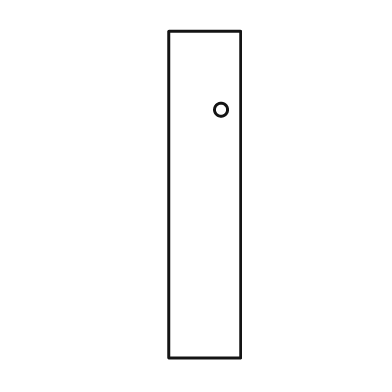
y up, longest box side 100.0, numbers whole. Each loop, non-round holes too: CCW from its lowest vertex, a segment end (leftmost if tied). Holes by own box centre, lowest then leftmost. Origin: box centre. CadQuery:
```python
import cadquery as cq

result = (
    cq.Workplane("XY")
    .moveTo(-11.0, -50.0)
    .lineTo(11.0, -50.0)
    .lineTo(11.0, 50.0)
    .lineTo(-11.0, 50.0)
    .close()
    .moveTo(5.0, 26.0)
    .circle(2.0)
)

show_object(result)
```